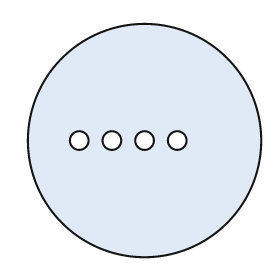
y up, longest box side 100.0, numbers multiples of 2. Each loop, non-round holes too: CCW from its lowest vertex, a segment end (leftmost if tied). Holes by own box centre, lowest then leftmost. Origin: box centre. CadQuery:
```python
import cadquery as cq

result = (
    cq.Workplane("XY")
    .moveTo(0.0, 0.0)
    .circle(50.0)
    .moveTo(-28.0, 0.0)
    .circle(4.0)
    .moveTo(-14.0, 0.0)
    .circle(4.0)
    .moveTo(0.0, 0.0)
    .circle(4.0)
    .moveTo(14.0, 0.0)
    .circle(4.0)
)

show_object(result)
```